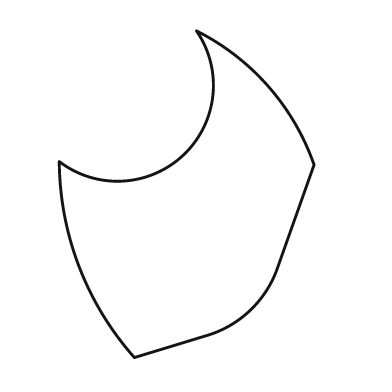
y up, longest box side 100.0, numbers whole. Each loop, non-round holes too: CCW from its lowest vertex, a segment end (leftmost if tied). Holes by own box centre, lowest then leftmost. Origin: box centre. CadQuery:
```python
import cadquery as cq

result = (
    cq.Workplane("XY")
    .moveTo(-16.0, -50.0)
    .lineTo(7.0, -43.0)
    .threePointArc((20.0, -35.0), (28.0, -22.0))
    .lineTo(39.0, 9.0)
    .threePointArc((25.0, 33.0), (3.0, 50.0))
    .threePointArc((-1.0, 12.0), (-39.0, 10.0))
    .threePointArc((-33.0, -22.0), (-16.0, -50.0))
    .close()
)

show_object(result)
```